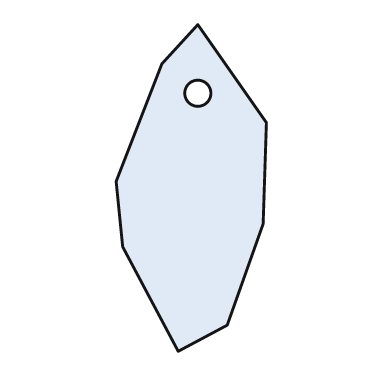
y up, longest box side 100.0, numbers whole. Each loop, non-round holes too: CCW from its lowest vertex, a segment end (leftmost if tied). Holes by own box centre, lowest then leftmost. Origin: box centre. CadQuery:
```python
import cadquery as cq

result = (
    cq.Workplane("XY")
    .moveTo(-4.0, -50.0)
    .lineTo(11.0, -42.0)
    .lineTo(22.0, -11.0)
    .lineTo(23.0, 20.0)
    .lineTo(2.0, 50.0)
    .lineTo(-9.0, 38.0)
    .lineTo(-23.0, 2.0)
    .lineTo(-21.0, -18.0)
    .close()
    .moveTo(2.0, 29.0)
    .circle(4.0)
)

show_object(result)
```